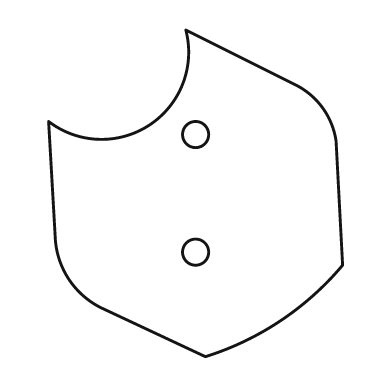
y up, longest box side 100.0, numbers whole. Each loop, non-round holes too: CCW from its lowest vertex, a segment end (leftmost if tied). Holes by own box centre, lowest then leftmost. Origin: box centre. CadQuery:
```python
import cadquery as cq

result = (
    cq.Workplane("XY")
    .moveTo(3.0, -50.0)
    .threePointArc((26.0, -39.0), (45.0, -22.0))
    .lineTo(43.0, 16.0)
    .threePointArc((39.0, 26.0), (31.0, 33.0))
    .lineTo(-3.0, 50.0)
    .threePointArc((-14.0, 21.0), (-45.0, 22.0))
    .lineTo(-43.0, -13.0)
    .threePointArc((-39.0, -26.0), (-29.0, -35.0))
    .close()
    .moveTo(0.0, -18.0)
    .circle(4.0)
    .moveTo(0.0, 18.0)
    .circle(4.0)
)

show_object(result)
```